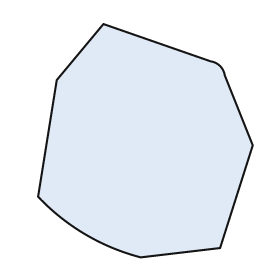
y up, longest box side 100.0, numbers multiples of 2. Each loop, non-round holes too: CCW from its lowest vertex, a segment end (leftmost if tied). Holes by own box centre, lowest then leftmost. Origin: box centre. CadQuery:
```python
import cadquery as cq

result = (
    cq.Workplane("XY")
    .moveTo(-2.0, -50.0)
    .lineTo(32.0, -46.0)
    .lineTo(46.0, -2.0)
    .lineTo(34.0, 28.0)
    .threePointArc((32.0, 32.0), (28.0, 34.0))
    .lineTo(-18.0, 50.0)
    .lineTo(-38.0, 26.0)
    .lineTo(-46.0, -24.0)
    .threePointArc((-26.0, -40.0), (-2.0, -50.0))
    .close()
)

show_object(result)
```